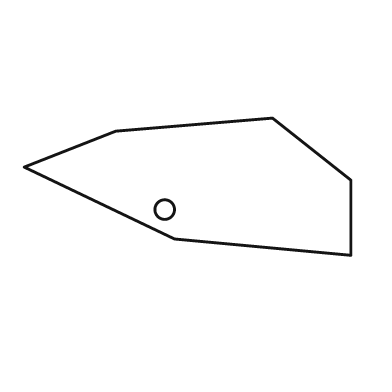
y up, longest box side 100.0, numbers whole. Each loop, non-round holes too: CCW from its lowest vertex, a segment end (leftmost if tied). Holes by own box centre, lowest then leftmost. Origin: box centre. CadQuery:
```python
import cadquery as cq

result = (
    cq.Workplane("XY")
    .moveTo(50.0, -21.0)
    .lineTo(50.0, 2.0)
    .lineTo(26.0, 21.0)
    .lineTo(-22.0, 17.0)
    .lineTo(-50.0, 6.0)
    .lineTo(-4.0, -16.0)
    .close()
    .moveTo(-7.0, -7.0)
    .circle(3.0)
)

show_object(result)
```